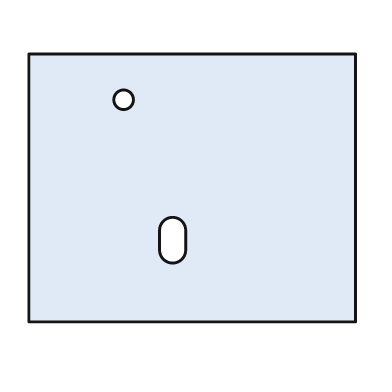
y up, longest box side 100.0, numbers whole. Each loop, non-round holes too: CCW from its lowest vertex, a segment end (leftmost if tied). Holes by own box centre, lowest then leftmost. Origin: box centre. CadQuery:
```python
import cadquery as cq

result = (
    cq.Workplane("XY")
    .moveTo(-50.0, -41.0)
    .lineTo(50.0, -41.0)
    .lineTo(50.0, 41.0)
    .lineTo(-50.0, 41.0)
    .close()
    .moveTo(-10.0, -19.0)
    .threePointArc((-6.0, -23.0), (-2.0, -19.0))
    .lineTo(-2.0, -13.0)
    .threePointArc((-6.0, -9.0), (-10.0, -13.0))
    .close()
    .moveTo(-21.0, 27.0)
    .circle(3.0)
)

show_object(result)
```